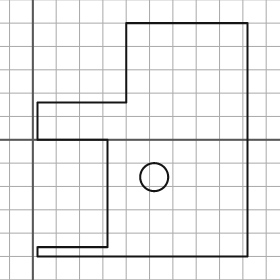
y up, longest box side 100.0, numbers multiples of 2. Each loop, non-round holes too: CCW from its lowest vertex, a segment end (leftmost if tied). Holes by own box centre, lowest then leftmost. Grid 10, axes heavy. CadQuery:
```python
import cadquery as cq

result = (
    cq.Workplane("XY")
    .moveTo(2.0, -50.0)
    .lineTo(92.0, -50.0)
    .lineTo(92.0, 50.0)
    .lineTo(40.0, 50.0)
    .lineTo(40.0, 16.0)
    .lineTo(2.0, 16.0)
    .lineTo(2.0, 0.0)
    .lineTo(32.0, 0.0)
    .lineTo(32.0, -46.0)
    .lineTo(2.0, -46.0)
    .close()
    .moveTo(52.0, -16.0)
    .circle(6.0)
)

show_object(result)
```